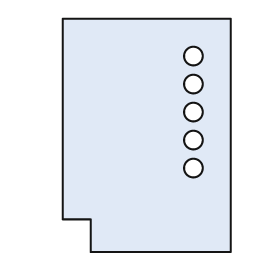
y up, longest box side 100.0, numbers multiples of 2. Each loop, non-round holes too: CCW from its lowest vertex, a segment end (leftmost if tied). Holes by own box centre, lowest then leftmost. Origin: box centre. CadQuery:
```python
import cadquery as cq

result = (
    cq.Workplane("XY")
    .moveTo(-24.0, -50.0)
    .lineTo(36.0, -50.0)
    .lineTo(36.0, 50.0)
    .lineTo(-36.0, 50.0)
    .lineTo(-36.0, -36.0)
    .lineTo(-24.0, -36.0)
    .close()
    .moveTo(20.0, -14.0)
    .circle(4.0)
    .moveTo(20.0, -2.0)
    .circle(4.0)
    .moveTo(20.0, 10.0)
    .circle(4.0)
    .moveTo(20.0, 22.0)
    .circle(4.0)
    .moveTo(20.0, 34.0)
    .circle(4.0)
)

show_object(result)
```